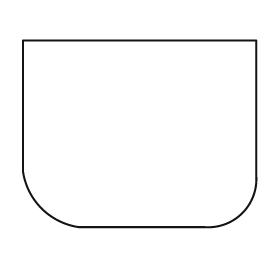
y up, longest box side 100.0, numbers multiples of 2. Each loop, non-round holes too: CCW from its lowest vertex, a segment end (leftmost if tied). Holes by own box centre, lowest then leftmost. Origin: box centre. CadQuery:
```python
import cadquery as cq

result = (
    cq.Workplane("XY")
    .moveTo(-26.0, -40.0)
    .lineTo(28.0, -40.0)
    .threePointArc((44.0, -34.0), (50.0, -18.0))
    .lineTo(50.0, 40.0)
    .lineTo(-50.0, 40.0)
    .lineTo(-50.0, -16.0)
    .threePointArc((-42.0, -32.0), (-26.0, -40.0))
    .close()
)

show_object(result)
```